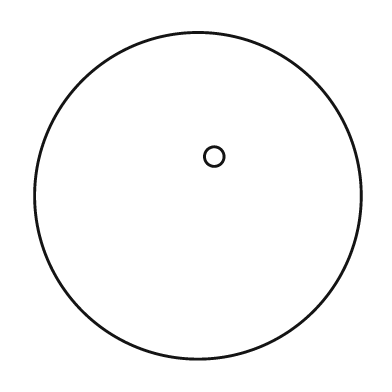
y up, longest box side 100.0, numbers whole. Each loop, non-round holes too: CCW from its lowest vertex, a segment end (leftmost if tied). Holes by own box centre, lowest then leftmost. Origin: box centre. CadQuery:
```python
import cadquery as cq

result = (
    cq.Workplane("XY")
    .moveTo(0.0, 0.0)
    .circle(50.0)
    .moveTo(5.0, 12.0)
    .circle(3.0)
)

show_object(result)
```